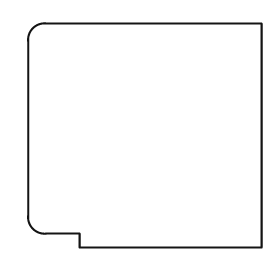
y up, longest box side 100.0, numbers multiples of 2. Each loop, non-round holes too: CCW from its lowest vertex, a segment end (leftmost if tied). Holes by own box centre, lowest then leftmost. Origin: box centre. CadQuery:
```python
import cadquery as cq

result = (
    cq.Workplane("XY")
    .moveTo(-28.0, -48.0)
    .lineTo(50.0, -48.0)
    .lineTo(50.0, 48.0)
    .lineTo(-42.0, 48.0)
    .threePointArc((-48.0, 46.0), (-50.0, 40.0))
    .lineTo(-50.0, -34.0)
    .threePointArc((-48.0, -40.0), (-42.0, -42.0))
    .lineTo(-28.0, -42.0)
    .close()
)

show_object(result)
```